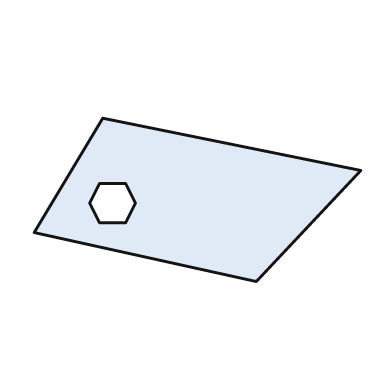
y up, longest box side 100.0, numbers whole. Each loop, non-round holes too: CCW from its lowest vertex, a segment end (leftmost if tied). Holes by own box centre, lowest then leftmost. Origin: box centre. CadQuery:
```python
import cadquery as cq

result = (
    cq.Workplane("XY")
    .moveTo(18.0, -25.0)
    .lineTo(50.0, 9.0)
    .lineTo(-29.0, 25.0)
    .lineTo(-50.0, -10.0)
    .close()
    .moveTo(-30.0, -7.0)
    .lineTo(-22.0, -7.0)
    .lineTo(-19.0, -1.0)
    .lineTo(-22.0, 5.0)
    .lineTo(-30.0, 5.0)
    .lineTo(-33.0, -1.0)
    .close()
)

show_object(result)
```